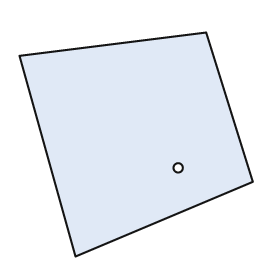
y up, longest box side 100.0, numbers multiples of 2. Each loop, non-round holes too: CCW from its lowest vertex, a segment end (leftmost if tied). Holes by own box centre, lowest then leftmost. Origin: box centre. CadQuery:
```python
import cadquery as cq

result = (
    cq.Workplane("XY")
    .moveTo(-26.0, -48.0)
    .lineTo(50.0, -16.0)
    .lineTo(30.0, 48.0)
    .lineTo(-50.0, 38.0)
    .close()
    .moveTo(18.0, -10.0)
    .circle(2.0)
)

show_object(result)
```